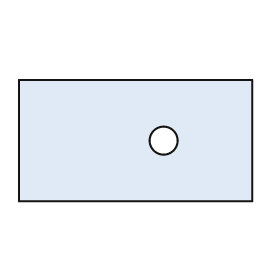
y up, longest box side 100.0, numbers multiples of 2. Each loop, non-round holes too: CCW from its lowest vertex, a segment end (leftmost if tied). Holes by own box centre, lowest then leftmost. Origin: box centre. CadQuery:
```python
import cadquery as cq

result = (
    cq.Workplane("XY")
    .moveTo(-50.0, -26.0)
    .lineTo(50.0, -26.0)
    .lineTo(50.0, 26.0)
    .lineTo(-50.0, 26.0)
    .close()
    .moveTo(12.0, 0.0)
    .circle(6.0)
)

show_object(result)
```